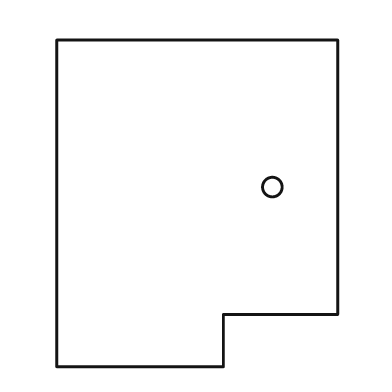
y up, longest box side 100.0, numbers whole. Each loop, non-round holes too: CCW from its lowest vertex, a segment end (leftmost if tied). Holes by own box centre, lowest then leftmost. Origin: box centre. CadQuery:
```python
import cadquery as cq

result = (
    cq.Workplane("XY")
    .moveTo(-43.0, -50.0)
    .lineTo(8.0, -50.0)
    .lineTo(8.0, -34.0)
    .lineTo(43.0, -34.0)
    .lineTo(43.0, 50.0)
    .lineTo(-43.0, 50.0)
    .close()
    .moveTo(23.0, 5.0)
    .circle(3.0)
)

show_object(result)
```